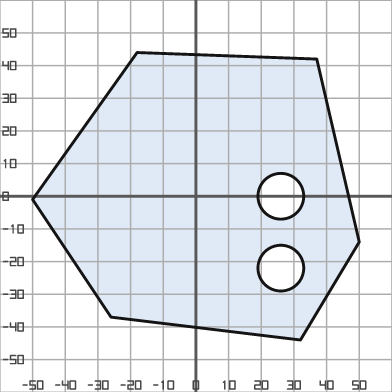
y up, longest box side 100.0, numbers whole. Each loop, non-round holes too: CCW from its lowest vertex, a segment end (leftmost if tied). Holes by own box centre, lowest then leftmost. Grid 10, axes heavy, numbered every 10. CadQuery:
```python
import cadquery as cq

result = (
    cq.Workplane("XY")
    .moveTo(32.0, -44.0)
    .lineTo(50.0, -14.0)
    .lineTo(37.0, 42.0)
    .lineTo(-18.0, 44.0)
    .lineTo(-50.0, -1.0)
    .lineTo(-26.0, -37.0)
    .close()
    .moveTo(26.0, -22.0)
    .circle(7.0)
    .moveTo(26.0, 0.0)
    .circle(7.0)
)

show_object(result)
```